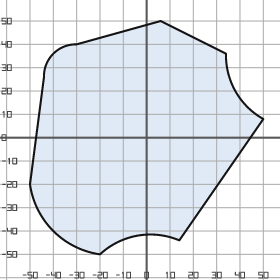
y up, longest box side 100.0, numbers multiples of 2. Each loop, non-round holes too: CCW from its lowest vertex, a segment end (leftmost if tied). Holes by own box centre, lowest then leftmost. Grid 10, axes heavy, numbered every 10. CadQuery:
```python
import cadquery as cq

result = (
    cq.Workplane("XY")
    .moveTo(-20.0, -50.0)
    .threePointArc((-4.0, -42.0), (14.0, -44.0))
    .lineTo(50.0, 8.0)
    .threePointArc((38.0, 20.0), (34.0, 36.0))
    .lineTo(6.0, 50.0)
    .lineTo(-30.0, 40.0)
    .threePointArc((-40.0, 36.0), (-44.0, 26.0))
    .lineTo(-50.0, -20.0)
    .threePointArc((-40.0, -40.0), (-20.0, -50.0))
    .close()
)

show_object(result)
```